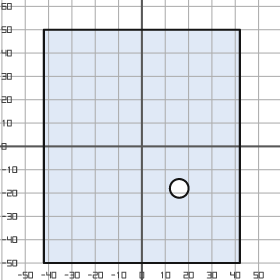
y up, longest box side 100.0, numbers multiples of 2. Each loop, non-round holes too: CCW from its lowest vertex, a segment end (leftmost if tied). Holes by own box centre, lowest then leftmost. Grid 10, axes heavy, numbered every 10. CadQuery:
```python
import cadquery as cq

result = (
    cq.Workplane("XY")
    .moveTo(-42.0, -50.0)
    .lineTo(42.0, -50.0)
    .lineTo(42.0, 50.0)
    .lineTo(-42.0, 50.0)
    .close()
    .moveTo(16.0, -18.0)
    .circle(4.0)
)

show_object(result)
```